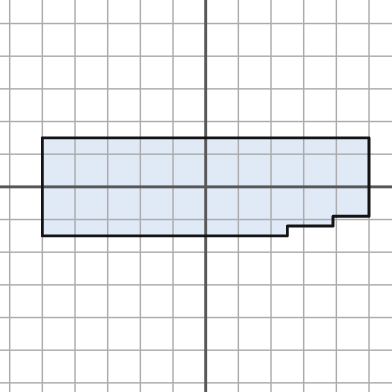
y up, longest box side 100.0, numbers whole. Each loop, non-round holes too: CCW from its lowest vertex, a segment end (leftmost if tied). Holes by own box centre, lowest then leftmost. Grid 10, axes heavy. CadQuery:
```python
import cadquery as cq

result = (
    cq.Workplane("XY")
    .moveTo(-50.0, -15.0)
    .lineTo(25.0, -15.0)
    .lineTo(25.0, -12.0)
    .lineTo(39.0, -12.0)
    .lineTo(39.0, -9.0)
    .lineTo(50.0, -9.0)
    .lineTo(50.0, 15.0)
    .lineTo(-50.0, 15.0)
    .close()
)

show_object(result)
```